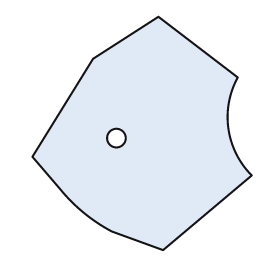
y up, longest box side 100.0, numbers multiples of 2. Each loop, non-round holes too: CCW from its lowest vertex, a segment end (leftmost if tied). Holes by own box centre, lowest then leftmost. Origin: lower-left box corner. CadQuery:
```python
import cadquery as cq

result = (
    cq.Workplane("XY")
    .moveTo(56.0, 0.0)
    .lineTo(94.0, 32.0)
    .threePointArc((84.0, 52.0), (88.0, 74.0))
    .lineTo(54.0, 100.0)
    .lineTo(26.0, 82.0)
    .lineTo(0.0, 40.0)
    .lineTo(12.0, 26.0)
    .threePointArc((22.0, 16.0), (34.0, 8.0))
    .close()
    .moveTo(36.0, 48.0)
    .circle(4.0)
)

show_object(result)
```